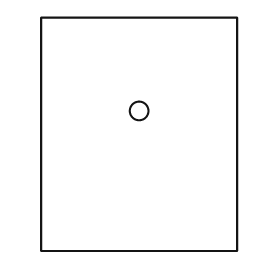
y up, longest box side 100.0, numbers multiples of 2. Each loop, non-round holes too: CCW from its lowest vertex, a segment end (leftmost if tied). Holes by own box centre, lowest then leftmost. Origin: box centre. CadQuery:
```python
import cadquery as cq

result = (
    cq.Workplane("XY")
    .moveTo(-42.0, -50.0)
    .lineTo(42.0, -50.0)
    .lineTo(42.0, 50.0)
    .lineTo(-42.0, 50.0)
    .close()
    .moveTo(0.0, 10.0)
    .circle(4.0)
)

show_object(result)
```